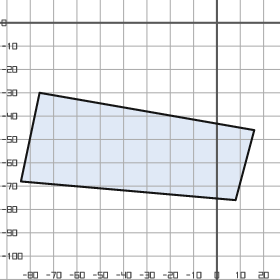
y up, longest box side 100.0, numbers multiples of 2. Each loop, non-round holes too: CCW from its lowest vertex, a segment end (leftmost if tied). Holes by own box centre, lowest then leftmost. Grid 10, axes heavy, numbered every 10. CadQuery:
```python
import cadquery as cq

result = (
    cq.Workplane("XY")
    .moveTo(8.0, -76.0)
    .lineTo(16.0, -46.0)
    .lineTo(-76.0, -30.0)
    .lineTo(-84.0, -68.0)
    .close()
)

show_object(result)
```